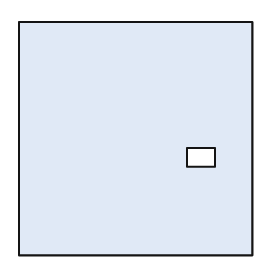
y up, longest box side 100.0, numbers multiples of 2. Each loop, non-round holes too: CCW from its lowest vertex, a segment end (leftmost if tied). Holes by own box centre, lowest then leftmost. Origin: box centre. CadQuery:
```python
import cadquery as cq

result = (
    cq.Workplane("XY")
    .moveTo(-50.0, -50.0)
    .lineTo(50.0, -50.0)
    .lineTo(50.0, 50.0)
    .lineTo(-50.0, 50.0)
    .close()
    .moveTo(22.0, -12.0)
    .lineTo(34.0, -12.0)
    .lineTo(34.0, -4.0)
    .lineTo(22.0, -4.0)
    .close()
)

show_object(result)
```